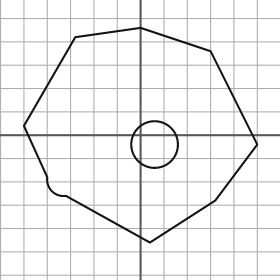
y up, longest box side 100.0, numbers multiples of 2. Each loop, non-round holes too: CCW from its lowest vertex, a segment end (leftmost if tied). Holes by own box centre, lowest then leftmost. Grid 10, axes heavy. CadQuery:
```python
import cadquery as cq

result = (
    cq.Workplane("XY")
    .moveTo(4.0, -46.0)
    .lineTo(32.0, -28.0)
    .lineTo(50.0, -4.0)
    .lineTo(30.0, 36.0)
    .lineTo(0.0, 46.0)
    .lineTo(-28.0, 42.0)
    .lineTo(-50.0, 4.0)
    .lineTo(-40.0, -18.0)
    .threePointArc((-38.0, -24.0), (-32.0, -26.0))
    .close()
    .moveTo(6.0, -4.0)
    .circle(10.0)
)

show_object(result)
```